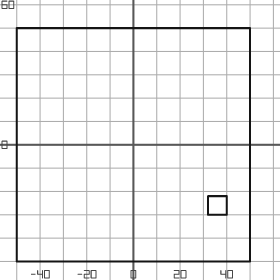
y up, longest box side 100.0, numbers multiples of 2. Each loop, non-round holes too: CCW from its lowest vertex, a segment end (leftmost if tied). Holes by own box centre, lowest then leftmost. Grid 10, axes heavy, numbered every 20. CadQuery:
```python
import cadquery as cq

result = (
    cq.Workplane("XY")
    .moveTo(-50.0, -50.0)
    .lineTo(50.0, -50.0)
    .lineTo(50.0, 50.0)
    .lineTo(-50.0, 50.0)
    .close()
    .moveTo(32.0, -30.0)
    .lineTo(40.0, -30.0)
    .lineTo(40.0, -22.0)
    .lineTo(32.0, -22.0)
    .close()
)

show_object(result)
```